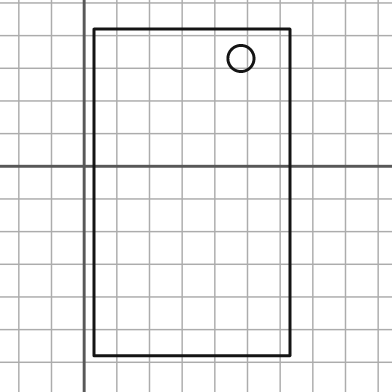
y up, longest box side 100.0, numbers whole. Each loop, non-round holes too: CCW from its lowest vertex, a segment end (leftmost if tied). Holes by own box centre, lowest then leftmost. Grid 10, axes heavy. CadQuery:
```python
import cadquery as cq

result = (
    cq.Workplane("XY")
    .moveTo(3.0, -58.0)
    .lineTo(63.0, -58.0)
    .lineTo(63.0, 42.0)
    .lineTo(3.0, 42.0)
    .close()
    .moveTo(48.0, 33.0)
    .circle(4.0)
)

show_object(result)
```